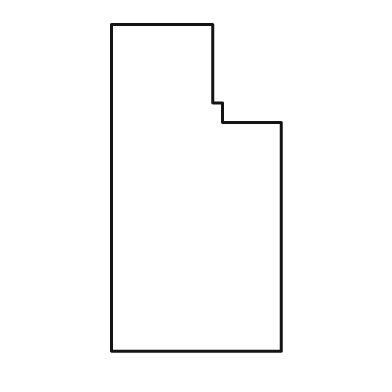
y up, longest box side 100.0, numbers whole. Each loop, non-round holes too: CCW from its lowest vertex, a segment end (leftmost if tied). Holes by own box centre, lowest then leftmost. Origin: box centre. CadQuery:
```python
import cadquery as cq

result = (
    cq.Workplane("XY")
    .moveTo(-26.0, -50.0)
    .lineTo(26.0, -50.0)
    .lineTo(26.0, 20.0)
    .lineTo(8.0, 20.0)
    .lineTo(8.0, 26.0)
    .lineTo(5.0, 26.0)
    .lineTo(5.0, 50.0)
    .lineTo(-26.0, 50.0)
    .close()
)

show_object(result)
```